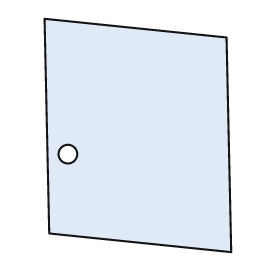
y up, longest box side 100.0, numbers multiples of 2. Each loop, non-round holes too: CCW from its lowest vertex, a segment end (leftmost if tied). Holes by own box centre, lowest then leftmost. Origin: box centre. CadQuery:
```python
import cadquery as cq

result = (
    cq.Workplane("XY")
    .moveTo(40.0, -50.0)
    .lineTo(38.0, 42.0)
    .lineTo(-40.0, 50.0)
    .lineTo(-38.0, -42.0)
    .close()
    .moveTo(-30.0, -8.0)
    .circle(4.0)
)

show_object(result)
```